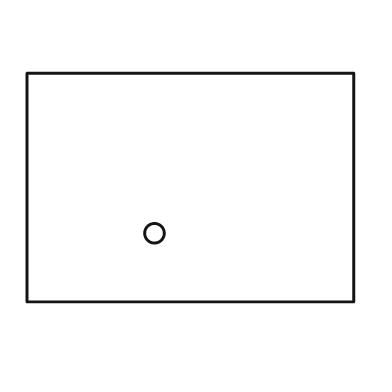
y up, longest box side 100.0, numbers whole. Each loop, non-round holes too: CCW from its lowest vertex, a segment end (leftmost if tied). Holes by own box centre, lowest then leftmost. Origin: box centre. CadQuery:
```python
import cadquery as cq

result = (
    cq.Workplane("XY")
    .moveTo(-50.0, -35.0)
    .lineTo(50.0, -35.0)
    .lineTo(50.0, 35.0)
    .lineTo(-50.0, 35.0)
    .close()
    .moveTo(-11.0, -14.0)
    .circle(3.0)
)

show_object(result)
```